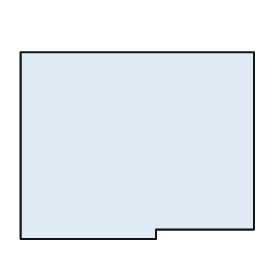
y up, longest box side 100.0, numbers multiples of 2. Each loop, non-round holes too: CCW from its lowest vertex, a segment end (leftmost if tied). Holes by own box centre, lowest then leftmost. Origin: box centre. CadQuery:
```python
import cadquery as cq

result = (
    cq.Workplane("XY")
    .moveTo(-50.0, -40.0)
    .lineTo(8.0, -40.0)
    .lineTo(8.0, -36.0)
    .lineTo(50.0, -36.0)
    .lineTo(50.0, 40.0)
    .lineTo(-50.0, 40.0)
    .close()
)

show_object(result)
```